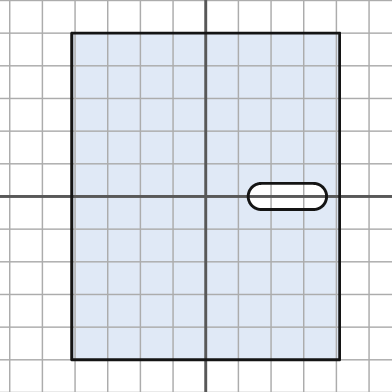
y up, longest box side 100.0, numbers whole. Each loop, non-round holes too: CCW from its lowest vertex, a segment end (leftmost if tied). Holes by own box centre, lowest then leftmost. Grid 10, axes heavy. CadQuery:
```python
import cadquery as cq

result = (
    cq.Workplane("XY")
    .moveTo(-41.0, -50.0)
    .lineTo(41.0, -50.0)
    .lineTo(41.0, 50.0)
    .lineTo(-41.0, 50.0)
    .close()
    .moveTo(17.0, -4.0)
    .lineTo(33.0, -4.0)
    .threePointArc((37.0, 0.0), (33.0, 4.0))
    .lineTo(17.0, 4.0)
    .threePointArc((13.0, 0.0), (17.0, -4.0))
    .close()
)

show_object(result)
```